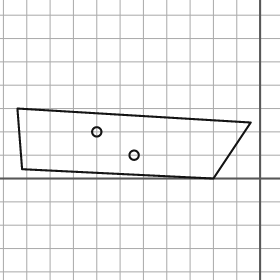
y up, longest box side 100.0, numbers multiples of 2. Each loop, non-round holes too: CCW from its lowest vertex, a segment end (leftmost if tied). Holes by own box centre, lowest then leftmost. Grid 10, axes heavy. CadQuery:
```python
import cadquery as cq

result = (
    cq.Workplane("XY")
    .moveTo(-20.0, 0.0)
    .lineTo(-4.0, 24.0)
    .lineTo(-104.0, 30.0)
    .lineTo(-102.0, 4.0)
    .close()
    .moveTo(-54.0, 10.0)
    .circle(2.0)
    .moveTo(-70.0, 20.0)
    .circle(2.0)
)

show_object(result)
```